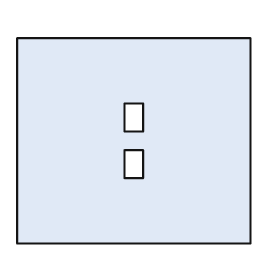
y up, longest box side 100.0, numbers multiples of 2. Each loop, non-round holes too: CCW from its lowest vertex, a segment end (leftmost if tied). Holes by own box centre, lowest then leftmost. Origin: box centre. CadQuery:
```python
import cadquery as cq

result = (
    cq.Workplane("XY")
    .moveTo(-50.0, -44.0)
    .lineTo(50.0, -44.0)
    .lineTo(50.0, 44.0)
    .lineTo(-50.0, 44.0)
    .close()
    .moveTo(-4.0, -16.0)
    .lineTo(4.0, -16.0)
    .lineTo(4.0, -4.0)
    .lineTo(-4.0, -4.0)
    .close()
    .moveTo(-4.0, 4.0)
    .lineTo(4.0, 4.0)
    .lineTo(4.0, 16.0)
    .lineTo(-4.0, 16.0)
    .close()
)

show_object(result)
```